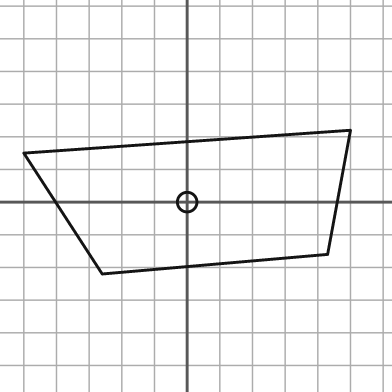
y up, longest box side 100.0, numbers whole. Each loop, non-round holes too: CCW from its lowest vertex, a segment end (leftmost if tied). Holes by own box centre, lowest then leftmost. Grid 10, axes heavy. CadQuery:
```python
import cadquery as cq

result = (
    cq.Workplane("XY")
    .moveTo(-26.0, -22.0)
    .lineTo(43.0, -16.0)
    .lineTo(50.0, 22.0)
    .lineTo(-50.0, 15.0)
    .close()
    .moveTo(0.0, 0.0)
    .circle(3.0)
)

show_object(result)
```